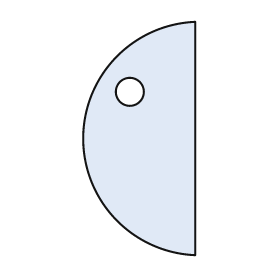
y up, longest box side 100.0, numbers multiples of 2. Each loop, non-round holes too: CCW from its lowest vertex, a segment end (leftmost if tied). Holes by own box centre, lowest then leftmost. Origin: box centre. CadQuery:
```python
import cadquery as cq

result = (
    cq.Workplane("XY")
    .moveTo(24.0, -50.0)
    .lineTo(24.0, 50.0)
    .threePointArc((-24.0, 0.0), (24.0, -50.0))
    .close()
    .moveTo(-4.0, 20.0)
    .circle(6.0)
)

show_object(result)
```